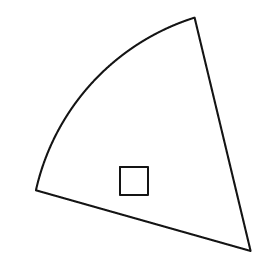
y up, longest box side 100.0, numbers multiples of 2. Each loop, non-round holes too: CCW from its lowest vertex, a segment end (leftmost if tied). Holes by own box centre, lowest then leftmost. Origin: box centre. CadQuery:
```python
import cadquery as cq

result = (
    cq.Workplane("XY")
    .moveTo(46.0, -50.0)
    .lineTo(22.0, 50.0)
    .threePointArc((-22.0, 22.0), (-46.0, -24.0))
    .close()
    .moveTo(-10.0, -26.0)
    .lineTo(2.0, -26.0)
    .lineTo(2.0, -14.0)
    .lineTo(-10.0, -14.0)
    .close()
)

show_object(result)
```